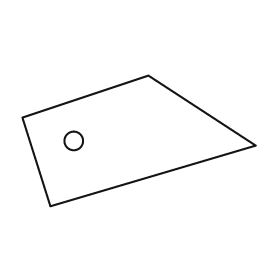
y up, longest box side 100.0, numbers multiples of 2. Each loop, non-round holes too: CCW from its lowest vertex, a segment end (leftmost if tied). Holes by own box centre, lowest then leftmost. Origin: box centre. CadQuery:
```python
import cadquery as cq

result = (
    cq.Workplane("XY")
    .moveTo(-38.0, -28.0)
    .lineTo(50.0, -2.0)
    .lineTo(4.0, 28.0)
    .lineTo(-50.0, 10.0)
    .close()
    .moveTo(-28.0, 0.0)
    .circle(4.0)
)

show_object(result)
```